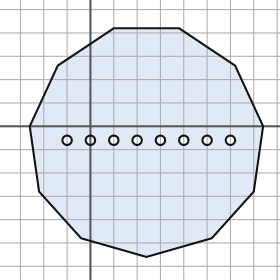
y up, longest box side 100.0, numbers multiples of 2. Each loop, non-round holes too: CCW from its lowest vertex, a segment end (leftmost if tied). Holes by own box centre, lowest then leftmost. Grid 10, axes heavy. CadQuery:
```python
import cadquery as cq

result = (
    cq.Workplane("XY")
    .moveTo(24.0, -56.0)
    .lineTo(52.0, -48.0)
    .lineTo(70.0, -28.0)
    .lineTo(74.0, 0.0)
    .lineTo(62.0, 26.0)
    .lineTo(38.0, 42.0)
    .lineTo(10.0, 42.0)
    .lineTo(-14.0, 26.0)
    .lineTo(-26.0, 0.0)
    .lineTo(-22.0, -28.0)
    .lineTo(-4.0, -48.0)
    .close()
    .moveTo(-10.0, -6.0)
    .circle(2.0)
    .moveTo(0.0, -6.0)
    .circle(2.0)
    .moveTo(10.0, -6.0)
    .circle(2.0)
    .moveTo(20.0, -6.0)
    .circle(2.0)
    .moveTo(30.0, -6.0)
    .circle(2.0)
    .moveTo(40.0, -6.0)
    .circle(2.0)
    .moveTo(50.0, -6.0)
    .circle(2.0)
    .moveTo(60.0, -6.0)
    .circle(2.0)
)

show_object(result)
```